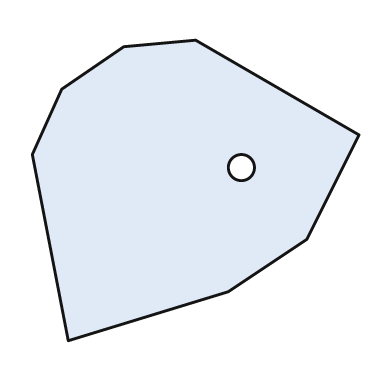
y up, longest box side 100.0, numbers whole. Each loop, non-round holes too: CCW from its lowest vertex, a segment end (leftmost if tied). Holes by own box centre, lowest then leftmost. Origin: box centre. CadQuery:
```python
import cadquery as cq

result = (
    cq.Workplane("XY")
    .moveTo(-39.0, -46.0)
    .lineTo(10.0, -31.0)
    .lineTo(34.0, -15.0)
    .lineTo(50.0, 17.0)
    .lineTo(0.0, 46.0)
    .lineTo(-22.0, 44.0)
    .lineTo(-41.0, 31.0)
    .lineTo(-50.0, 11.0)
    .close()
    .moveTo(14.0, 7.0)
    .circle(4.0)
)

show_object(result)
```